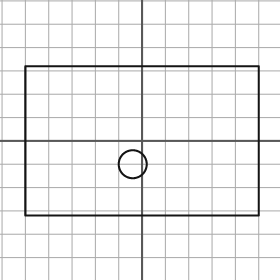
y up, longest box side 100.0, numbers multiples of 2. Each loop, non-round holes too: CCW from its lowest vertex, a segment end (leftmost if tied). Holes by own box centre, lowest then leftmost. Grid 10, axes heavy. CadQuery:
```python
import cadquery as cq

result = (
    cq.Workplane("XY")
    .moveTo(-50.0, -32.0)
    .lineTo(50.0, -32.0)
    .lineTo(50.0, 32.0)
    .lineTo(-50.0, 32.0)
    .close()
    .moveTo(-4.0, -10.0)
    .circle(6.0)
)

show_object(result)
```